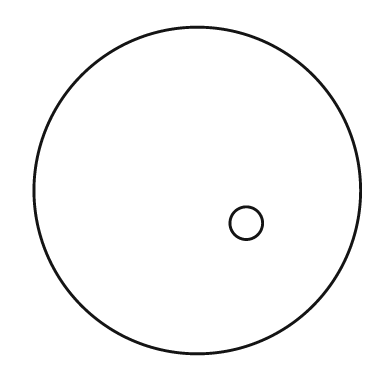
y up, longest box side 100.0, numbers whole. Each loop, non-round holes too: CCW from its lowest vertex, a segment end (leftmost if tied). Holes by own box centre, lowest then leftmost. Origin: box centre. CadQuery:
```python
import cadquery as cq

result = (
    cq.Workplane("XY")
    .moveTo(0.0, 0.0)
    .circle(50.0)
    .moveTo(15.0, -10.0)
    .circle(5.0)
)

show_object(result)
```